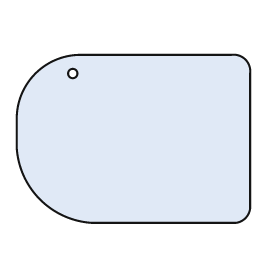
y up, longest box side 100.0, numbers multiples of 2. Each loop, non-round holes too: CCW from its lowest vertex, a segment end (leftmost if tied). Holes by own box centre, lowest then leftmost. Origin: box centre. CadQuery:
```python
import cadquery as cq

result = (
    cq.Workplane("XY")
    .moveTo(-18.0, -36.0)
    .lineTo(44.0, -36.0)
    .threePointArc((48.0, -34.0), (50.0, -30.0))
    .lineTo(50.0, 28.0)
    .threePointArc((48.0, 34.0), (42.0, 36.0))
    .lineTo(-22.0, 36.0)
    .threePointArc((-42.0, 28.0), (-50.0, 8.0))
    .lineTo(-50.0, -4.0)
    .threePointArc((-40.0, -26.0), (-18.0, -36.0))
    .close()
    .moveTo(-26.0, 28.0)
    .circle(2.0)
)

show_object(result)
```